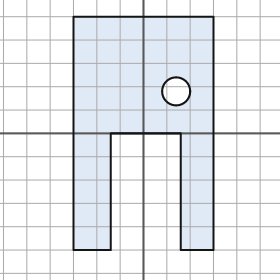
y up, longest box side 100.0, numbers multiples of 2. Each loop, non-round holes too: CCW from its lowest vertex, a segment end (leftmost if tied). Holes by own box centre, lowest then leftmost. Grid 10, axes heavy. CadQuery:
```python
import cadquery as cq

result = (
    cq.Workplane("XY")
    .moveTo(-30.0, -50.0)
    .lineTo(-14.0, -50.0)
    .lineTo(-14.0, 0.0)
    .lineTo(16.0, 0.0)
    .lineTo(16.0, -50.0)
    .lineTo(30.0, -50.0)
    .lineTo(30.0, 50.0)
    .lineTo(-30.0, 50.0)
    .close()
    .moveTo(14.0, 18.0)
    .circle(6.0)
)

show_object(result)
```